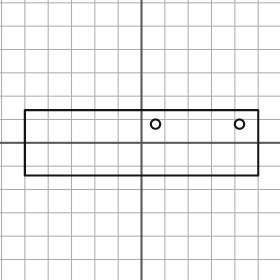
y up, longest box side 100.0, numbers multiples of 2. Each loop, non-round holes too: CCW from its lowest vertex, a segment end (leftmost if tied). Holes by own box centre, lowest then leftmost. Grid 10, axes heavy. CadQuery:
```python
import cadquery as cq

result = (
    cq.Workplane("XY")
    .moveTo(-50.0, -14.0)
    .lineTo(50.0, -14.0)
    .lineTo(50.0, 14.0)
    .lineTo(-50.0, 14.0)
    .close()
    .moveTo(6.0, 8.0)
    .circle(2.0)
    .moveTo(42.0, 8.0)
    .circle(2.0)
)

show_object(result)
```